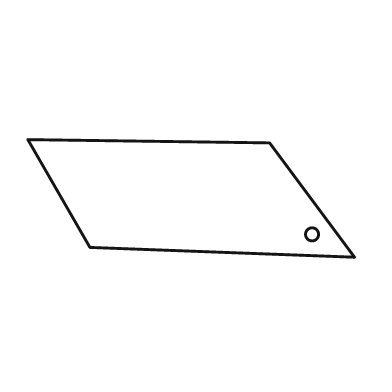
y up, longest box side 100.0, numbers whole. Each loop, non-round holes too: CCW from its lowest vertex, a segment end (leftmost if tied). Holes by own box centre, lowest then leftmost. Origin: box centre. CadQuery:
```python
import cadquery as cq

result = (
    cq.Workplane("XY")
    .moveTo(50.0, -18.0)
    .lineTo(24.0, 17.0)
    .lineTo(-50.0, 18.0)
    .lineTo(-31.0, -15.0)
    .close()
    .moveTo(37.0, -11.0)
    .circle(2.0)
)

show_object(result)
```